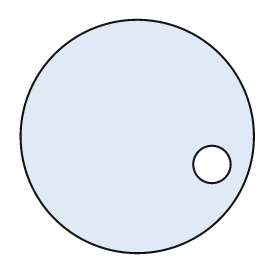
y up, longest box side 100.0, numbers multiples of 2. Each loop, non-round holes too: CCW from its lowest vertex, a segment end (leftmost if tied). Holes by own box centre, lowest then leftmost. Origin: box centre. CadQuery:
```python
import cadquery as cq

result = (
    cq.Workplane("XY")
    .moveTo(0.0, 0.0)
    .circle(50.0)
    .moveTo(32.0, -12.0)
    .circle(8.0)
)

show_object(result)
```